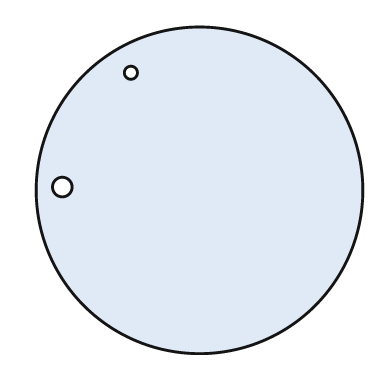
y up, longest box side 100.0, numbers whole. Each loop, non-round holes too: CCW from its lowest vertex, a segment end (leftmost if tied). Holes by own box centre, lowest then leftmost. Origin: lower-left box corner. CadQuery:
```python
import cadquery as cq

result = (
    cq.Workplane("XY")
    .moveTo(50.0, 50.0)
    .circle(50.0)
    .moveTo(8.0, 51.0)
    .circle(3.0)
    .moveTo(29.0, 86.0)
    .circle(2.0)
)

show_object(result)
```